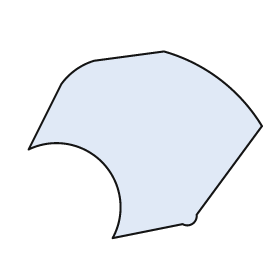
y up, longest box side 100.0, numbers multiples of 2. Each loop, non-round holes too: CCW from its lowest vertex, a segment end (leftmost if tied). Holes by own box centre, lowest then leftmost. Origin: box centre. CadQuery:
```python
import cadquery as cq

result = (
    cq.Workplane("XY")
    .moveTo(-14.0, -40.0)
    .lineTo(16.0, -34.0)
    .threePointArc((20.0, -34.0), (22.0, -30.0))
    .lineTo(50.0, 8.0)
    .threePointArc((32.0, 28.0), (8.0, 40.0))
    .lineTo(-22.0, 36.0)
    .threePointArc((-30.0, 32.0), (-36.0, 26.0))
    .lineTo(-50.0, -2.0)
    .threePointArc((-18.0, -8.0), (-14.0, -40.0))
    .close()
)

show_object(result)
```